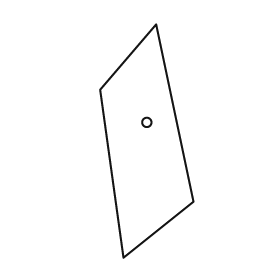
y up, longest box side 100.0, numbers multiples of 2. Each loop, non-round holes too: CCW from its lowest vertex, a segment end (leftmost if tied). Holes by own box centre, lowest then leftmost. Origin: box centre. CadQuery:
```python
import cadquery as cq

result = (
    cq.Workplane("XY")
    .moveTo(-10.0, -50.0)
    .lineTo(20.0, -26.0)
    .lineTo(4.0, 50.0)
    .lineTo(-20.0, 22.0)
    .close()
    .moveTo(0.0, 8.0)
    .circle(2.0)
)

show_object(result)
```